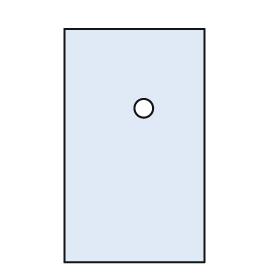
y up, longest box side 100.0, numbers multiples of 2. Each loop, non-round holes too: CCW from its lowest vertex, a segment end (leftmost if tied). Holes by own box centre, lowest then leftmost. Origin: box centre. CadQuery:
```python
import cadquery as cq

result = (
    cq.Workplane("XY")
    .moveTo(-30.0, -50.0)
    .lineTo(30.0, -50.0)
    .lineTo(30.0, 50.0)
    .lineTo(-30.0, 50.0)
    .close()
    .moveTo(4.0, 16.0)
    .circle(4.0)
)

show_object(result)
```